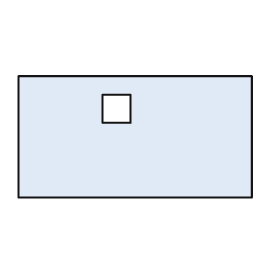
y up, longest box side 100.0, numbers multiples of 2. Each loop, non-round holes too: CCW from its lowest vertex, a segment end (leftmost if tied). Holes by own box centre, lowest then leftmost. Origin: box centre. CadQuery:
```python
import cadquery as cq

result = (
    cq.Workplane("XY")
    .moveTo(-50.0, -26.0)
    .lineTo(50.0, -26.0)
    .lineTo(50.0, 26.0)
    .lineTo(-50.0, 26.0)
    .close()
    .moveTo(-14.0, 6.0)
    .lineTo(-2.0, 6.0)
    .lineTo(-2.0, 18.0)
    .lineTo(-14.0, 18.0)
    .close()
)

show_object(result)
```